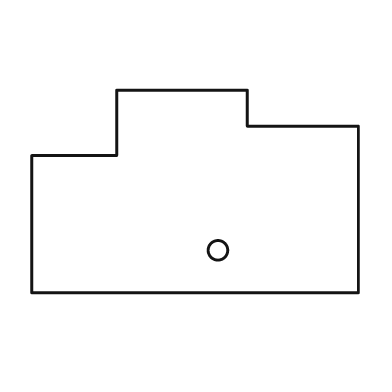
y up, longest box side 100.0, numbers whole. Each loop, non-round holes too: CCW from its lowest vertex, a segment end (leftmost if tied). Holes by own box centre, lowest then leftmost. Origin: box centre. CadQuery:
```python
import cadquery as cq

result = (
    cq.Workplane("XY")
    .moveTo(-50.0, -31.0)
    .lineTo(50.0, -31.0)
    .lineTo(50.0, 20.0)
    .lineTo(16.0, 20.0)
    .lineTo(16.0, 31.0)
    .lineTo(-24.0, 31.0)
    .lineTo(-24.0, 11.0)
    .lineTo(-50.0, 11.0)
    .close()
    .moveTo(7.0, -18.0)
    .circle(3.0)
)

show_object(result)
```